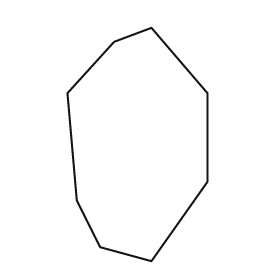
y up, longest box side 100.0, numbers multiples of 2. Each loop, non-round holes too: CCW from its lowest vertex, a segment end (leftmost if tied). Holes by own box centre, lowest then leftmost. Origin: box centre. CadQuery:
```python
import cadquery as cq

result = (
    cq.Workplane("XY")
    .moveTo(6.0, -50.0)
    .lineTo(30.0, -16.0)
    .lineTo(30.0, 22.0)
    .lineTo(6.0, 50.0)
    .lineTo(-10.0, 44.0)
    .lineTo(-30.0, 22.0)
    .lineTo(-26.0, -24.0)
    .lineTo(-16.0, -44.0)
    .close()
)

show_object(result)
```